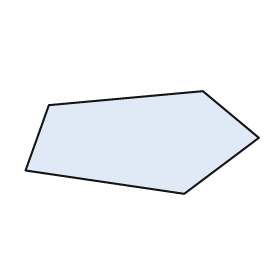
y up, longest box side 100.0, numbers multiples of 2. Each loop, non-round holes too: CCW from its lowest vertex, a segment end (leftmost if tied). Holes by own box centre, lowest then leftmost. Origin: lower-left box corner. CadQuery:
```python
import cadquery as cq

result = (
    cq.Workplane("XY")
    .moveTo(68.0, 0.0)
    .lineTo(100.0, 24.0)
    .lineTo(76.0, 44.0)
    .lineTo(10.0, 38.0)
    .lineTo(0.0, 10.0)
    .close()
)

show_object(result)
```